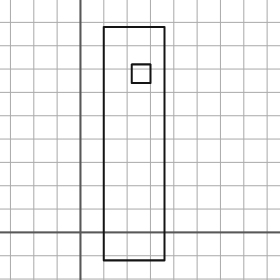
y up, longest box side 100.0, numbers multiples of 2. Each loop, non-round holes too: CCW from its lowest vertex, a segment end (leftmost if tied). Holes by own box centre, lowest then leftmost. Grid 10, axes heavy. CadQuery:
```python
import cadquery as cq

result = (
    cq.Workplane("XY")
    .moveTo(10.0, -12.0)
    .lineTo(36.0, -12.0)
    .lineTo(36.0, 88.0)
    .lineTo(10.0, 88.0)
    .close()
    .moveTo(22.0, 64.0)
    .lineTo(30.0, 64.0)
    .lineTo(30.0, 72.0)
    .lineTo(22.0, 72.0)
    .close()
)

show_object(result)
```